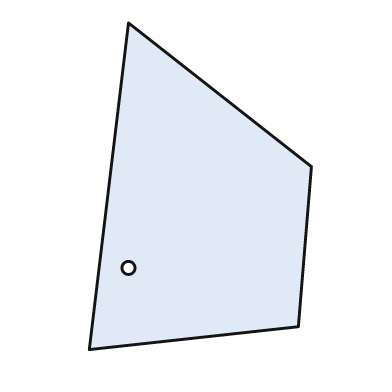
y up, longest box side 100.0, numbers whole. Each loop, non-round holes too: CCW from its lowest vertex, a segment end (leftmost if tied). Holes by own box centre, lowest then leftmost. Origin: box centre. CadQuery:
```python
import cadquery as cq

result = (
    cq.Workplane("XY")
    .moveTo(-34.0, -50.0)
    .lineTo(30.0, -43.0)
    .lineTo(34.0, 6.0)
    .lineTo(-22.0, 50.0)
    .close()
    .moveTo(-22.0, -25.0)
    .circle(2.0)
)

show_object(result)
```